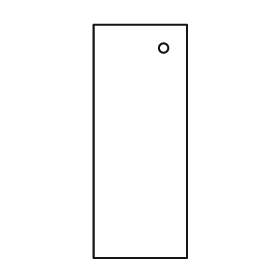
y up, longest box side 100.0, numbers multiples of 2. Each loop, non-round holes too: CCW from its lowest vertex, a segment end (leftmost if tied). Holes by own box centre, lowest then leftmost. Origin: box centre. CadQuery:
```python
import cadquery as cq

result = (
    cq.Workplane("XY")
    .moveTo(-20.0, -50.0)
    .lineTo(20.0, -50.0)
    .lineTo(20.0, 50.0)
    .lineTo(-20.0, 50.0)
    .close()
    .moveTo(10.0, 40.0)
    .circle(2.0)
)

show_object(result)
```